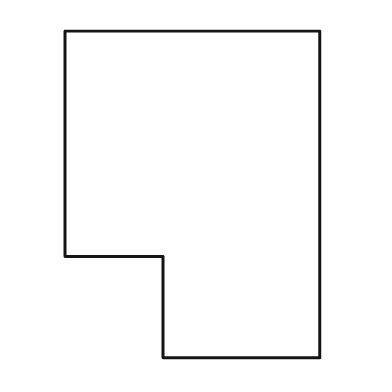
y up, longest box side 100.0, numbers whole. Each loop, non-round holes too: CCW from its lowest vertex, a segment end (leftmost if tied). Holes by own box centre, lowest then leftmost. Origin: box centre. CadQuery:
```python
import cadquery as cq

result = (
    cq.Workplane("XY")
    .moveTo(-9.0, -50.0)
    .lineTo(39.0, -50.0)
    .lineTo(39.0, 50.0)
    .lineTo(-39.0, 50.0)
    .lineTo(-39.0, -19.0)
    .lineTo(-9.0, -19.0)
    .close()
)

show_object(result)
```